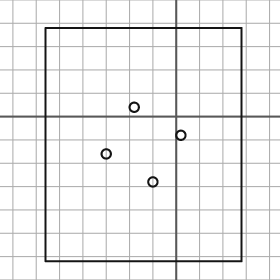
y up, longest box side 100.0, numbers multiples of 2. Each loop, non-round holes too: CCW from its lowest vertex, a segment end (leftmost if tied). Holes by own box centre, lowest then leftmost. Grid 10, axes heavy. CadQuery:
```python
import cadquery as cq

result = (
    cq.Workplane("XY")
    .moveTo(-56.0, -62.0)
    .lineTo(28.0, -62.0)
    .lineTo(28.0, 38.0)
    .lineTo(-56.0, 38.0)
    .close()
    .moveTo(-10.0, -28.0)
    .circle(2.0)
    .moveTo(-30.0, -16.0)
    .circle(2.0)
    .moveTo(2.0, -8.0)
    .circle(2.0)
    .moveTo(-18.0, 4.0)
    .circle(2.0)
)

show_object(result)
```